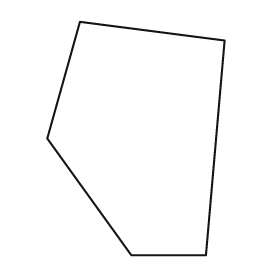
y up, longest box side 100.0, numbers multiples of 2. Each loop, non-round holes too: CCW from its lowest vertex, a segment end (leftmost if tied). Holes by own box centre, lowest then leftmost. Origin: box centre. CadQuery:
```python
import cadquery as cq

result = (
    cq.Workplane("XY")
    .moveTo(-2.0, -50.0)
    .lineTo(30.0, -50.0)
    .lineTo(38.0, 42.0)
    .lineTo(-24.0, 50.0)
    .lineTo(-38.0, 0.0)
    .close()
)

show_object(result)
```